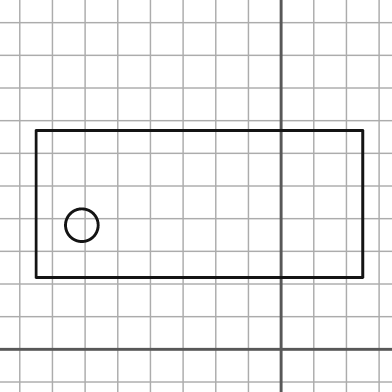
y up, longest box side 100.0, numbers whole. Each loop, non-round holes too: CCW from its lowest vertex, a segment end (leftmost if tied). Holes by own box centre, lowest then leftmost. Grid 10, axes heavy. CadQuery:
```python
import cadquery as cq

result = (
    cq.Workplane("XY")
    .moveTo(-75.0, 22.0)
    .lineTo(25.0, 22.0)
    .lineTo(25.0, 67.0)
    .lineTo(-75.0, 67.0)
    .close()
    .moveTo(-61.0, 38.0)
    .circle(5.0)
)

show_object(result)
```